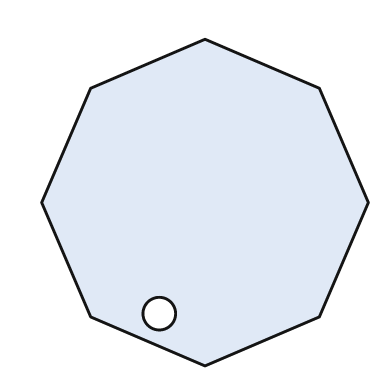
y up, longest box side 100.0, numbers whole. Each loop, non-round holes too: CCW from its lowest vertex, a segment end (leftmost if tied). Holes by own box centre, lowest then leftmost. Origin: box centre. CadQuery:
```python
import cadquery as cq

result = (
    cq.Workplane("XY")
    .moveTo(0.0, -50.0)
    .lineTo(35.0, -35.0)
    .lineTo(50.0, 0.0)
    .lineTo(35.0, 35.0)
    .lineTo(0.0, 50.0)
    .lineTo(-35.0, 35.0)
    .lineTo(-50.0, 0.0)
    .lineTo(-35.0, -35.0)
    .close()
    .moveTo(-14.0, -34.0)
    .circle(5.0)
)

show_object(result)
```